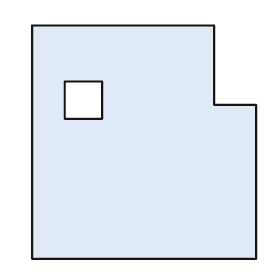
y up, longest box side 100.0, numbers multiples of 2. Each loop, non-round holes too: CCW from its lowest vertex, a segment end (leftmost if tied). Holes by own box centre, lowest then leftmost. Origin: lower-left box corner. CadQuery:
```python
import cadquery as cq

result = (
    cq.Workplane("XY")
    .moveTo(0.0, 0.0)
    .lineTo(96.0, 0.0)
    .lineTo(96.0, 66.0)
    .lineTo(78.0, 66.0)
    .lineTo(78.0, 100.0)
    .lineTo(0.0, 100.0)
    .close()
    .moveTo(14.0, 60.0)
    .lineTo(30.0, 60.0)
    .lineTo(30.0, 76.0)
    .lineTo(14.0, 76.0)
    .close()
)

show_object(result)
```